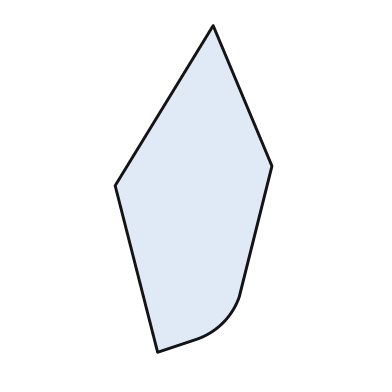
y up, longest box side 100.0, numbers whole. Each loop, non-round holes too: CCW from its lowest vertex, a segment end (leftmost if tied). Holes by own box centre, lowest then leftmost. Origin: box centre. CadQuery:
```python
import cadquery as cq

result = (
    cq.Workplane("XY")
    .moveTo(-11.0, -50.0)
    .lineTo(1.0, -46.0)
    .threePointArc((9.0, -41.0), (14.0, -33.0))
    .lineTo(24.0, 7.0)
    .lineTo(6.0, 50.0)
    .lineTo(-24.0, 1.0)
    .close()
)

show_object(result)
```